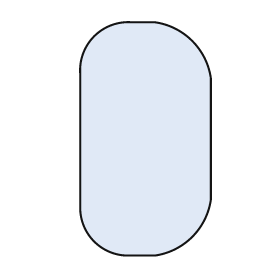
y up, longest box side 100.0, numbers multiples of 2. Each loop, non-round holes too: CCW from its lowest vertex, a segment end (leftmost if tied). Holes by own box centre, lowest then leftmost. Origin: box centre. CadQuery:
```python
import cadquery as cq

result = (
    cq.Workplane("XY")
    .moveTo(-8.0, -50.0)
    .lineTo(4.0, -50.0)
    .threePointArc((20.0, -42.0), (28.0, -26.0))
    .lineTo(28.0, 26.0)
    .threePointArc((20.0, 42.0), (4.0, 50.0))
    .lineTo(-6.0, 50.0)
    .threePointArc((-22.0, 44.0), (-28.0, 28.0))
    .lineTo(-28.0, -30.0)
    .threePointArc((-22.0, -44.0), (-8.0, -50.0))
    .close()
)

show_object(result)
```